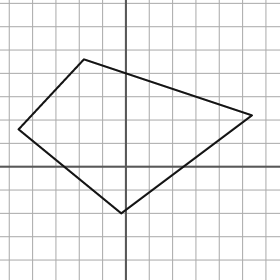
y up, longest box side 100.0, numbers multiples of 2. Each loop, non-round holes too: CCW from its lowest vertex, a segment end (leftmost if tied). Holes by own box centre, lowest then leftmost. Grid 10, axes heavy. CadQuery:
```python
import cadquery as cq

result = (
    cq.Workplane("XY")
    .moveTo(-2.0, -20.0)
    .lineTo(54.0, 22.0)
    .lineTo(-18.0, 46.0)
    .lineTo(-46.0, 16.0)
    .close()
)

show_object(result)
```